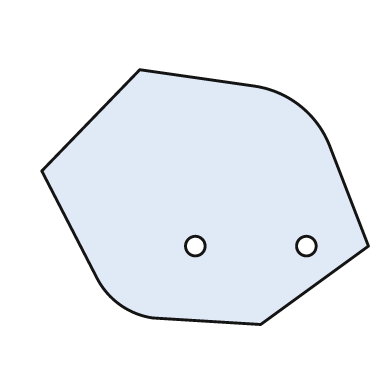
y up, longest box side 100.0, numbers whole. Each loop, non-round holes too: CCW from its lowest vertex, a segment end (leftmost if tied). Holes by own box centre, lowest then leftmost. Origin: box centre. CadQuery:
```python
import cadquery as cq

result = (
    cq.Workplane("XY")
    .moveTo(17.0, -39.0)
    .lineTo(50.0, -15.0)
    .lineTo(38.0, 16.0)
    .threePointArc((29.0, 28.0), (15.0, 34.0))
    .lineTo(-20.0, 39.0)
    .lineTo(-50.0, 8.0)
    .lineTo(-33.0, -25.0)
    .threePointArc((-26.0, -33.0), (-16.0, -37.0))
    .close()
    .moveTo(-3.0, -15.0)
    .circle(3.0)
    .moveTo(31.0, -15.0)
    .circle(3.0)
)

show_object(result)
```